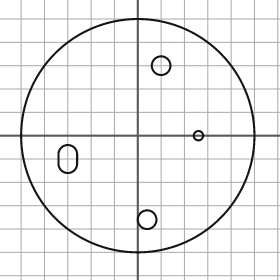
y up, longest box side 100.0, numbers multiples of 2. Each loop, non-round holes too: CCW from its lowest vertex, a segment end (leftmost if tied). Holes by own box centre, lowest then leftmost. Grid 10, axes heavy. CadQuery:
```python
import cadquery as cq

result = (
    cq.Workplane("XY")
    .moveTo(0.0, 0.0)
    .circle(50.0)
    .moveTo(4.0, -36.0)
    .circle(4.0)
    .moveTo(-34.0, -12.0)
    .threePointArc((-30.0, -16.0), (-26.0, -12.0))
    .lineTo(-26.0, -8.0)
    .threePointArc((-30.0, -4.0), (-34.0, -8.0))
    .close()
    .moveTo(26.0, 0.0)
    .circle(2.0)
    .moveTo(10.0, 30.0)
    .circle(4.0)
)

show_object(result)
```